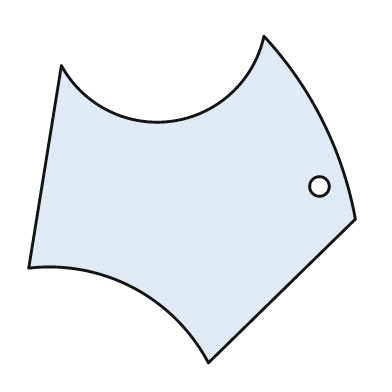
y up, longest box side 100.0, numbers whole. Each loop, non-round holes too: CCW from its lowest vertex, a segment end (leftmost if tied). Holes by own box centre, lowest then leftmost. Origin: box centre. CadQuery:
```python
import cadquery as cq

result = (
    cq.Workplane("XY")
    .moveTo(5.0, -50.0)
    .lineTo(50.0, -6.0)
    .threePointArc((40.0, 24.0), (22.0, 50.0))
    .threePointArc((-6.0, 24.0), (-40.0, 41.0))
    .lineTo(-50.0, -21.0)
    .threePointArc((-18.0, -27.0), (5.0, -50.0))
    .close()
    .moveTo(39.0, 4.0)
    .circle(3.0)
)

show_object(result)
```